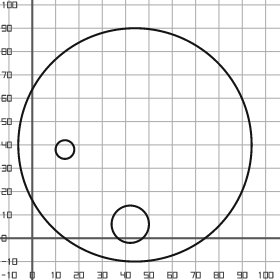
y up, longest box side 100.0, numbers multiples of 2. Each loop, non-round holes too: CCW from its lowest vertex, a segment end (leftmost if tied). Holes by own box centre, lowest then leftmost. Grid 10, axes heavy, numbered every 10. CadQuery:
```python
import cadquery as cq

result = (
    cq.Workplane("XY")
    .moveTo(44.0, 40.0)
    .circle(50.0)
    .moveTo(42.0, 6.0)
    .circle(8.0)
    .moveTo(14.0, 38.0)
    .circle(4.0)
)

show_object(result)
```